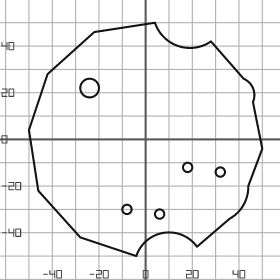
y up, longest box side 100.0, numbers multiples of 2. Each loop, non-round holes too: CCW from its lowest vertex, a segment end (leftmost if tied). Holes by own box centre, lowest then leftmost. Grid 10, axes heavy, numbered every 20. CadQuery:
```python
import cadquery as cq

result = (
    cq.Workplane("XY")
    .moveTo(-4.0, -50.0)
    .threePointArc((8.0, -40.0), (22.0, -46.0))
    .lineTo(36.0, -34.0)
    .threePointArc((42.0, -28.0), (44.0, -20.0))
    .lineTo(50.0, -4.0)
    .lineTo(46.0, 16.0)
    .threePointArc((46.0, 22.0), (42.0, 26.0))
    .lineTo(28.0, 42.0)
    .threePointArc((14.0, 40.0), (4.0, 50.0))
    .lineTo(-22.0, 46.0)
    .lineTo(-42.0, 28.0)
    .lineTo(-50.0, 4.0)
    .lineTo(-46.0, -22.0)
    .lineTo(-28.0, -42.0)
    .close()
    .moveTo(6.0, -32.0)
    .circle(2.0)
    .moveTo(-8.0, -30.0)
    .circle(2.0)
    .moveTo(32.0, -14.0)
    .circle(2.0)
    .moveTo(18.0, -12.0)
    .circle(2.0)
    .moveTo(-24.0, 22.0)
    .circle(4.0)
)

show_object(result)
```